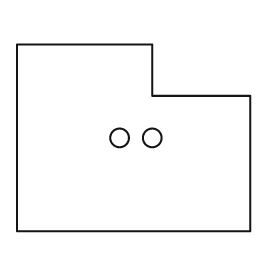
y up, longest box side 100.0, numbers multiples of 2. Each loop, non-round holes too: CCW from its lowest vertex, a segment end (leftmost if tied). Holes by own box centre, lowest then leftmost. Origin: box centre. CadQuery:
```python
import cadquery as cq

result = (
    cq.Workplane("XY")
    .moveTo(-50.0, -40.0)
    .lineTo(50.0, -40.0)
    .lineTo(50.0, 18.0)
    .lineTo(8.0, 18.0)
    .lineTo(8.0, 40.0)
    .lineTo(-50.0, 40.0)
    .close()
    .moveTo(-6.0, 0.0)
    .circle(4.0)
    .moveTo(8.0, 0.0)
    .circle(4.0)
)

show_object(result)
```